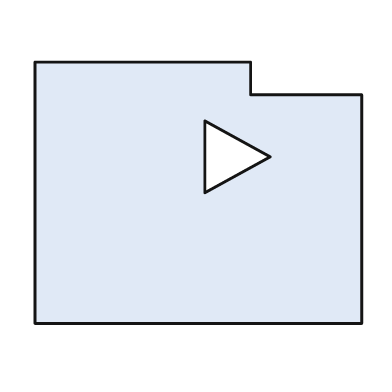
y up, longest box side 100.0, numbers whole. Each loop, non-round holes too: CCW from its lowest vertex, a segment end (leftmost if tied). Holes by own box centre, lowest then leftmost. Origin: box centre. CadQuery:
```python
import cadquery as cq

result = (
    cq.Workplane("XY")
    .moveTo(-50.0, -40.0)
    .lineTo(50.0, -40.0)
    .lineTo(50.0, 30.0)
    .lineTo(16.0, 30.0)
    .lineTo(16.0, 40.0)
    .lineTo(-50.0, 40.0)
    .close()
    .moveTo(2.0, 0.0)
    .lineTo(22.0, 11.0)
    .lineTo(2.0, 22.0)
    .close()
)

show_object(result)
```